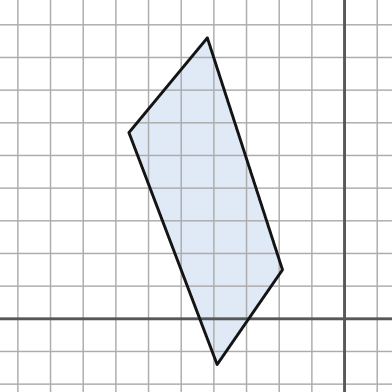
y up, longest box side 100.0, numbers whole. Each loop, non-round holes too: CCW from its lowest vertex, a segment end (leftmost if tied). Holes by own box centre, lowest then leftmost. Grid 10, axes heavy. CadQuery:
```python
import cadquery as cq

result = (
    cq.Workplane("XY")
    .moveTo(-39.0, -14.0)
    .lineTo(-19.0, 15.0)
    .lineTo(-42.0, 86.0)
    .lineTo(-66.0, 57.0)
    .close()
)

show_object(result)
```